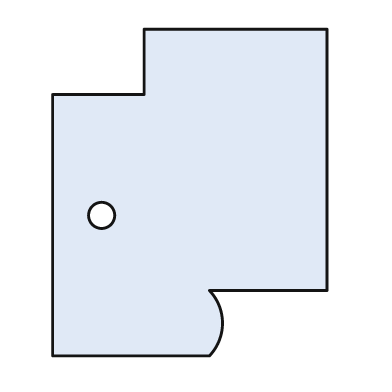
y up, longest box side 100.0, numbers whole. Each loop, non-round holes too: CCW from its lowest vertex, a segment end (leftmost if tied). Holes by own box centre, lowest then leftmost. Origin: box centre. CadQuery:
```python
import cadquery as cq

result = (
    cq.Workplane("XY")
    .moveTo(-42.0, -50.0)
    .lineTo(6.0, -50.0)
    .threePointArc((10.0, -40.0), (6.0, -30.0))
    .lineTo(42.0, -30.0)
    .lineTo(42.0, 50.0)
    .lineTo(-14.0, 50.0)
    .lineTo(-14.0, 30.0)
    .lineTo(-42.0, 30.0)
    .close()
    .moveTo(-27.0, -7.0)
    .circle(4.0)
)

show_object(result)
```